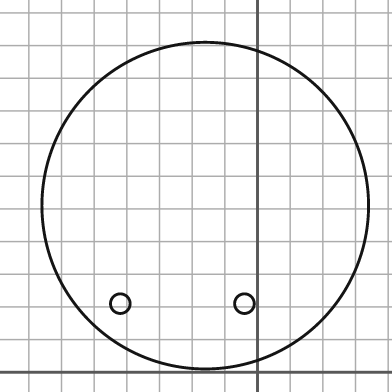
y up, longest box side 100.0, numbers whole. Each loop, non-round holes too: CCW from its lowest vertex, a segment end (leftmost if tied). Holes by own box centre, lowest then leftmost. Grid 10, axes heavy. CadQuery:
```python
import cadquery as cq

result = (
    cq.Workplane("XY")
    .moveTo(-16.0, 51.0)
    .circle(50.0)
    .moveTo(-42.0, 21.0)
    .circle(3.0)
    .moveTo(-4.0, 21.0)
    .circle(3.0)
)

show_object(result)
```